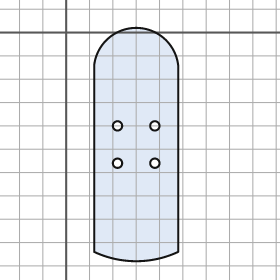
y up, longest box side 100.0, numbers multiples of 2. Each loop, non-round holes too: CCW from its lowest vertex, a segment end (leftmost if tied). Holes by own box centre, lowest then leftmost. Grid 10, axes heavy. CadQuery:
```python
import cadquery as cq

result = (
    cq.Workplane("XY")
    .moveTo(12.0, -94.0)
    .threePointArc((30.0, -98.0), (48.0, -94.0))
    .lineTo(48.0, -14.0)
    .threePointArc((30.0, 2.0), (12.0, -14.0))
    .close()
    .moveTo(22.0, -56.0)
    .circle(2.0)
    .moveTo(38.0, -56.0)
    .circle(2.0)
    .moveTo(22.0, -40.0)
    .circle(2.0)
    .moveTo(38.0, -40.0)
    .circle(2.0)
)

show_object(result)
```